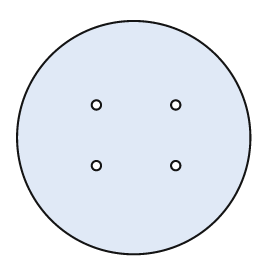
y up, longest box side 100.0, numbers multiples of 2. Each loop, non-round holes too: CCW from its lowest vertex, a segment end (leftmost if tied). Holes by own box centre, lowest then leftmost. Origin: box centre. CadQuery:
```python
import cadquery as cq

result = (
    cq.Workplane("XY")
    .moveTo(0.0, 0.0)
    .circle(50.0)
    .moveTo(-16.0, -12.0)
    .circle(2.0)
    .moveTo(18.0, -12.0)
    .circle(2.0)
    .moveTo(-16.0, 14.0)
    .circle(2.0)
    .moveTo(18.0, 14.0)
    .circle(2.0)
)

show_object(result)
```